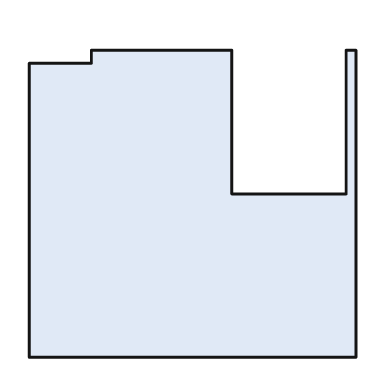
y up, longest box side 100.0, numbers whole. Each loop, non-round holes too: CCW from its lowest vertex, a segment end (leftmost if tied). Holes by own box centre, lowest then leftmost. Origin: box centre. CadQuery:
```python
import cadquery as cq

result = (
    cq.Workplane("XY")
    .moveTo(-50.0, -47.0)
    .lineTo(50.0, -47.0)
    .lineTo(50.0, 47.0)
    .lineTo(47.0, 47.0)
    .lineTo(47.0, 3.0)
    .lineTo(12.0, 3.0)
    .lineTo(12.0, 47.0)
    .lineTo(-31.0, 47.0)
    .lineTo(-31.0, 43.0)
    .lineTo(-50.0, 43.0)
    .close()
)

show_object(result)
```